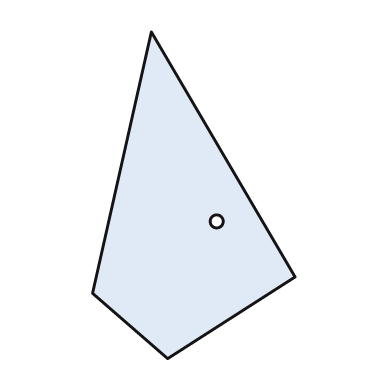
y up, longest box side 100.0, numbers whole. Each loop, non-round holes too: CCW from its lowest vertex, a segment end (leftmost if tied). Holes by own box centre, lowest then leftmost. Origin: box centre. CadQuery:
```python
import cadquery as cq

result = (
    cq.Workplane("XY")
    .moveTo(-8.0, -50.0)
    .lineTo(31.0, -25.0)
    .lineTo(-13.0, 50.0)
    .lineTo(-31.0, -30.0)
    .close()
    .moveTo(7.0, -8.0)
    .circle(2.0)
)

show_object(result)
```